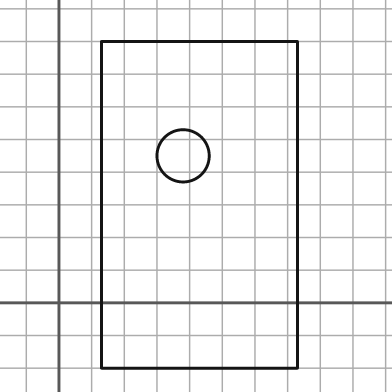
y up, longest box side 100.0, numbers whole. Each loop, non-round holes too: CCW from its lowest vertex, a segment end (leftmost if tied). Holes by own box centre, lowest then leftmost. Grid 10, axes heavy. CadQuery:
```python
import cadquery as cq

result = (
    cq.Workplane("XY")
    .moveTo(13.0, -20.0)
    .lineTo(73.0, -20.0)
    .lineTo(73.0, 80.0)
    .lineTo(13.0, 80.0)
    .close()
    .moveTo(38.0, 45.0)
    .circle(8.0)
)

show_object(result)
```